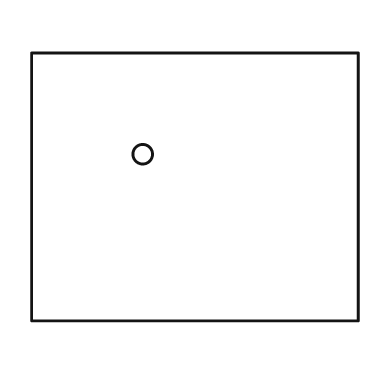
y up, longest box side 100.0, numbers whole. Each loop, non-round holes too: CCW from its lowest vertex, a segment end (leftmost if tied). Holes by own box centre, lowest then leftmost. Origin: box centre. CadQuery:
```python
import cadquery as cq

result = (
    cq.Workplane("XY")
    .moveTo(-50.0, -41.0)
    .lineTo(50.0, -41.0)
    .lineTo(50.0, 41.0)
    .lineTo(-50.0, 41.0)
    .close()
    .moveTo(-16.0, 10.0)
    .circle(3.0)
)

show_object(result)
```